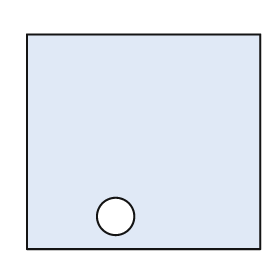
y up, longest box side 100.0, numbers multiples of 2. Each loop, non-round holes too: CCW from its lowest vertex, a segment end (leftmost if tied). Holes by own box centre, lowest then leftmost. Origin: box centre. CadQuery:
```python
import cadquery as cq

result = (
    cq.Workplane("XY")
    .moveTo(-50.0, -46.0)
    .lineTo(50.0, -46.0)
    .lineTo(50.0, 46.0)
    .lineTo(-50.0, 46.0)
    .close()
    .moveTo(-12.0, -32.0)
    .circle(8.0)
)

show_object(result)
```